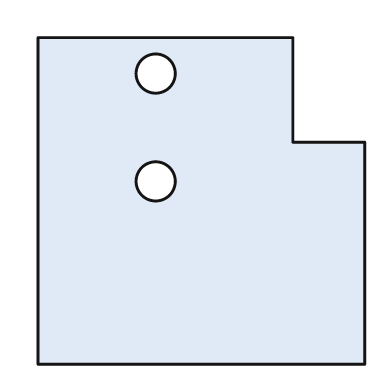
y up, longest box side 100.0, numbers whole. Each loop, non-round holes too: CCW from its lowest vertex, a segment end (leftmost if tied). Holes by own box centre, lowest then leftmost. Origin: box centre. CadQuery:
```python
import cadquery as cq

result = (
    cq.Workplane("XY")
    .moveTo(-50.0, -50.0)
    .lineTo(50.0, -50.0)
    .lineTo(50.0, 18.0)
    .lineTo(28.0, 18.0)
    .lineTo(28.0, 50.0)
    .lineTo(-50.0, 50.0)
    .close()
    .moveTo(-14.0, 6.0)
    .circle(6.0)
    .moveTo(-14.0, 39.0)
    .circle(6.0)
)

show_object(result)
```